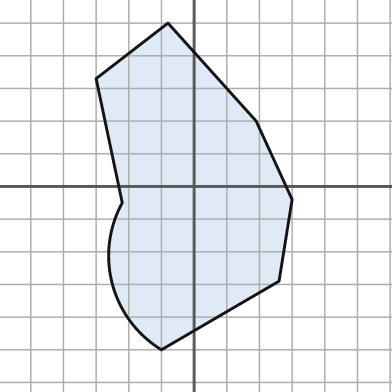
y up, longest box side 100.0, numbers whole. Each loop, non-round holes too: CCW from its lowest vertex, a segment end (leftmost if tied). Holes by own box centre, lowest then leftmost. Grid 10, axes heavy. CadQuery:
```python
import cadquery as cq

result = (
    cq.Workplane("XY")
    .moveTo(-10.0, -50.0)
    .lineTo(26.0, -29.0)
    .lineTo(30.0, -4.0)
    .lineTo(19.0, 20.0)
    .lineTo(-8.0, 50.0)
    .lineTo(-30.0, 33.0)
    .lineTo(-22.0, -5.0)
    .threePointArc((-25.0, -30.0), (-10.0, -50.0))
    .close()
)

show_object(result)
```